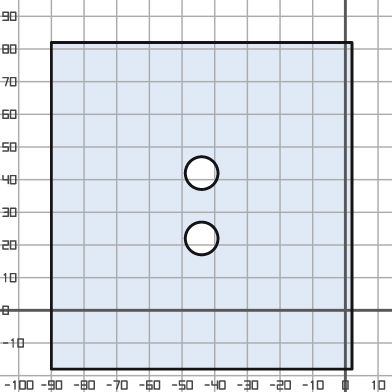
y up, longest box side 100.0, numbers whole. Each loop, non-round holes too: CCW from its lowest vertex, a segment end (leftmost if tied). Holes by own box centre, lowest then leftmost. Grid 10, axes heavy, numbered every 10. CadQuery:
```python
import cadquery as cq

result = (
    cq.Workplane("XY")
    .moveTo(-90.0, -18.0)
    .lineTo(2.0, -18.0)
    .lineTo(2.0, 82.0)
    .lineTo(-90.0, 82.0)
    .close()
    .moveTo(-44.0, 22.0)
    .circle(5.0)
    .moveTo(-44.0, 42.0)
    .circle(5.0)
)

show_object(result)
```